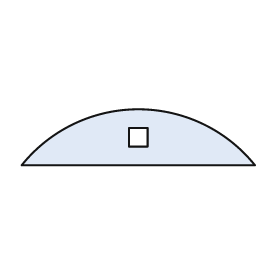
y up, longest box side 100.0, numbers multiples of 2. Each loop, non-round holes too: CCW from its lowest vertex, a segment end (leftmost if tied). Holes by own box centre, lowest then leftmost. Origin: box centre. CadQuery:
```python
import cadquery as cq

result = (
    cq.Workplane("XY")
    .moveTo(-50.0, -12.0)
    .lineTo(50.0, -12.0)
    .threePointArc((0.0, 12.0), (-50.0, -12.0))
    .close()
    .moveTo(-4.0, -4.0)
    .lineTo(4.0, -4.0)
    .lineTo(4.0, 4.0)
    .lineTo(-4.0, 4.0)
    .close()
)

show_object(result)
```